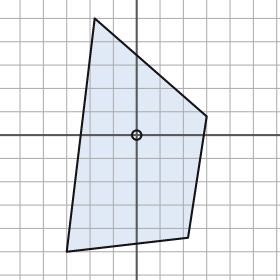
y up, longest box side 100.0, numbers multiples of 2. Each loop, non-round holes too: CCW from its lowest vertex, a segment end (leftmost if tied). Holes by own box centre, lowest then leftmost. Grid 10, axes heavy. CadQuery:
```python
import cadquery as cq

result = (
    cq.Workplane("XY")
    .moveTo(-30.0, -50.0)
    .lineTo(22.0, -44.0)
    .lineTo(30.0, 8.0)
    .lineTo(-18.0, 50.0)
    .close()
    .moveTo(0.0, 0.0)
    .circle(2.0)
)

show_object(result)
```